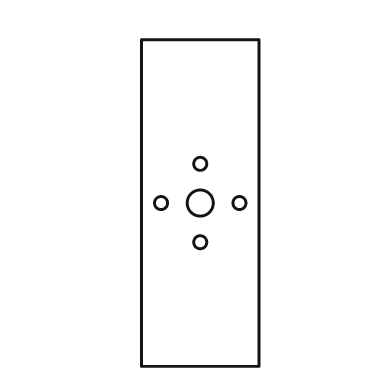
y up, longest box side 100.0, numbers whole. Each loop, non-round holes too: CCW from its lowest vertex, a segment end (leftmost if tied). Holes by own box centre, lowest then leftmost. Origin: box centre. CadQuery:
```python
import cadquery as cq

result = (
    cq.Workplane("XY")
    .moveTo(-18.0, -50.0)
    .lineTo(18.0, -50.0)
    .lineTo(18.0, 50.0)
    .lineTo(-18.0, 50.0)
    .close()
    .moveTo(0.0, -12.0)
    .circle(2.0)
    .moveTo(-12.0, 0.0)
    .circle(2.0)
    .moveTo(0.0, 0.0)
    .circle(4.0)
    .moveTo(12.0, 0.0)
    .circle(2.0)
    .moveTo(0.0, 12.0)
    .circle(2.0)
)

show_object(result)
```